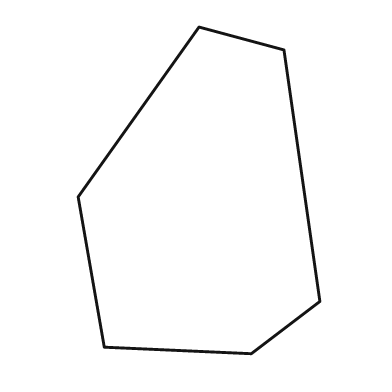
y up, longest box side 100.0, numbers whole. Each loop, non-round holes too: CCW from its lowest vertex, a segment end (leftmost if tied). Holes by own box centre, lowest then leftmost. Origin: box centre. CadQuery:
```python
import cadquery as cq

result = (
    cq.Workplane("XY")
    .moveTo(16.0, -50.0)
    .lineTo(37.0, -34.0)
    .lineTo(26.0, 43.0)
    .lineTo(0.0, 50.0)
    .lineTo(-37.0, -2.0)
    .lineTo(-29.0, -48.0)
    .close()
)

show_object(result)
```